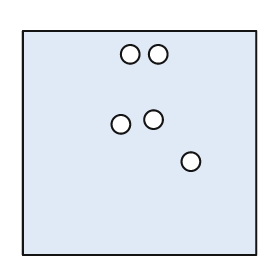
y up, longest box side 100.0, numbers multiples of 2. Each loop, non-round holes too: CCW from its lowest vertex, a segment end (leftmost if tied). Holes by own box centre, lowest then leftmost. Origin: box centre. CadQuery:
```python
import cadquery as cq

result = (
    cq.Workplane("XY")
    .moveTo(-50.0, -48.0)
    .lineTo(50.0, -48.0)
    .lineTo(50.0, 48.0)
    .lineTo(-50.0, 48.0)
    .close()
    .moveTo(22.0, -8.0)
    .circle(4.0)
    .moveTo(-8.0, 8.0)
    .circle(4.0)
    .moveTo(6.0, 10.0)
    .circle(4.0)
    .moveTo(-4.0, 38.0)
    .circle(4.0)
    .moveTo(8.0, 38.0)
    .circle(4.0)
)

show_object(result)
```